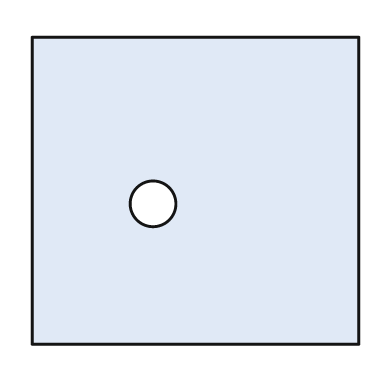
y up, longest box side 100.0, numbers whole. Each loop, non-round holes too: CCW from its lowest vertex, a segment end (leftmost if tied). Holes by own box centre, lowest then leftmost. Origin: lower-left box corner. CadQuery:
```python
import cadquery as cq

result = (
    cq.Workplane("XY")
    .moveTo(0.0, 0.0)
    .lineTo(100.0, 0.0)
    .lineTo(100.0, 94.0)
    .lineTo(0.0, 94.0)
    .close()
    .moveTo(37.0, 43.0)
    .circle(7.0)
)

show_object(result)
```